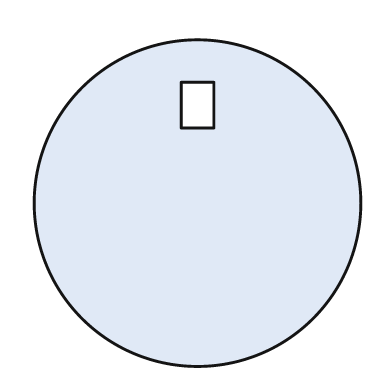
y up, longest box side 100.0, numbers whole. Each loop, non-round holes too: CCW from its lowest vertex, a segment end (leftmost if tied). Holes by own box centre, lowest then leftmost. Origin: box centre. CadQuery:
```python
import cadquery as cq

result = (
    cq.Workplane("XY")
    .moveTo(0.0, 0.0)
    .circle(50.0)
    .moveTo(-5.0, 23.0)
    .lineTo(5.0, 23.0)
    .lineTo(5.0, 37.0)
    .lineTo(-5.0, 37.0)
    .close()
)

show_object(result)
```